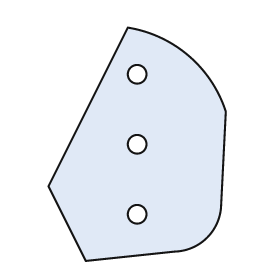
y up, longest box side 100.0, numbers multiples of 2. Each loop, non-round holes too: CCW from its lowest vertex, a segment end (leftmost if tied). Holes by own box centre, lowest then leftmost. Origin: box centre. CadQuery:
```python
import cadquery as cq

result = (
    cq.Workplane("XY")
    .moveTo(-22.0, -50.0)
    .lineTo(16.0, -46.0)
    .threePointArc((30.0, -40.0), (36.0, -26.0))
    .lineTo(38.0, 14.0)
    .threePointArc((22.0, 38.0), (-4.0, 50.0))
    .lineTo(-38.0, -18.0)
    .close()
    .moveTo(0.0, -30.0)
    .circle(4.0)
    .moveTo(0.0, 0.0)
    .circle(4.0)
    .moveTo(0.0, 30.0)
    .circle(4.0)
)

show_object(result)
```